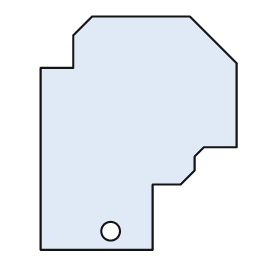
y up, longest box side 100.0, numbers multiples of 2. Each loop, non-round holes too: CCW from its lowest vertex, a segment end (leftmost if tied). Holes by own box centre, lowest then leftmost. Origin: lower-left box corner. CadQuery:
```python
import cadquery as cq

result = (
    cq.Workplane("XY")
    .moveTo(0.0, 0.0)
    .lineTo(48.0, 0.0)
    .lineTo(48.0, 28.0)
    .lineTo(60.0, 28.0)
    .lineTo(66.0, 34.0)
    .lineTo(66.0, 40.0)
    .lineTo(70.0, 44.0)
    .lineTo(84.0, 44.0)
    .lineTo(84.0, 80.0)
    .lineTo(64.0, 100.0)
    .lineTo(22.0, 100.0)
    .lineTo(14.0, 92.0)
    .lineTo(14.0, 78.0)
    .lineTo(0.0, 78.0)
    .close()
    .moveTo(30.0, 8.0)
    .circle(4.0)
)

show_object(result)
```